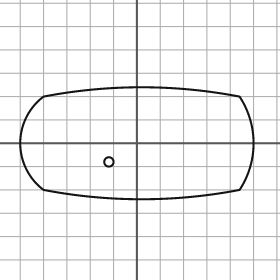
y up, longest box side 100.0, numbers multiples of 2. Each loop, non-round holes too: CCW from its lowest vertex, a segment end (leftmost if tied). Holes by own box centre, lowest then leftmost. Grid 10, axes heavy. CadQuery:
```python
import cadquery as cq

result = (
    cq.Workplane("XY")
    .moveTo(-40.0, -20.0)
    .threePointArc((2.0, -24.0), (44.0, -20.0))
    .threePointArc((50.0, 0.0), (44.0, 20.0))
    .threePointArc((2.0, 24.0), (-40.0, 20.0))
    .threePointArc((-50.0, 0.0), (-40.0, -20.0))
    .close()
    .moveTo(-12.0, -8.0)
    .circle(2.0)
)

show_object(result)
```